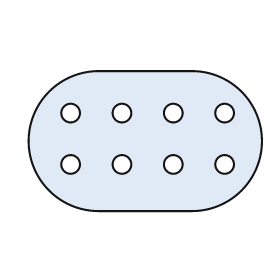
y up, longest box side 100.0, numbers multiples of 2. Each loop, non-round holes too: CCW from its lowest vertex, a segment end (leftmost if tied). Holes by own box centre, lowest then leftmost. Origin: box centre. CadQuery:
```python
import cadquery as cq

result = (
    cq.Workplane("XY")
    .moveTo(-20.0, -30.0)
    .lineTo(20.0, -30.0)
    .threePointArc((50.0, 0.0), (20.0, 30.0))
    .lineTo(-20.0, 30.0)
    .threePointArc((-50.0, 0.0), (-20.0, -30.0))
    .close()
    .moveTo(-32.0, -10.0)
    .circle(4.0)
    .moveTo(-10.0, -10.0)
    .circle(4.0)
    .moveTo(12.0, -10.0)
    .circle(4.0)
    .moveTo(34.0, -10.0)
    .circle(4.0)
    .moveTo(-32.0, 12.0)
    .circle(4.0)
    .moveTo(-10.0, 12.0)
    .circle(4.0)
    .moveTo(12.0, 12.0)
    .circle(4.0)
    .moveTo(34.0, 12.0)
    .circle(4.0)
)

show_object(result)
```